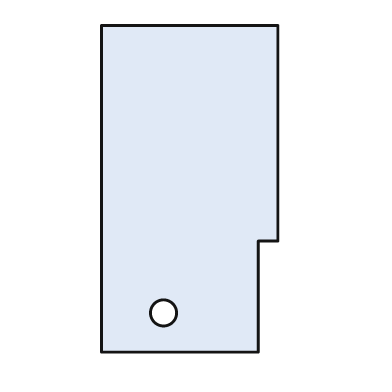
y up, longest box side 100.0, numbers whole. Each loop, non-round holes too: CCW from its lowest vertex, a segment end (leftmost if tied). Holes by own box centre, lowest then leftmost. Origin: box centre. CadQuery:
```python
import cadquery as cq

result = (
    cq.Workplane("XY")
    .moveTo(-27.0, -50.0)
    .lineTo(21.0, -50.0)
    .lineTo(21.0, -16.0)
    .lineTo(27.0, -16.0)
    .lineTo(27.0, 50.0)
    .lineTo(-27.0, 50.0)
    .close()
    .moveTo(-8.0, -38.0)
    .circle(4.0)
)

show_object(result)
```